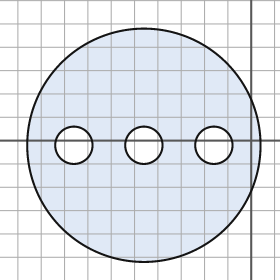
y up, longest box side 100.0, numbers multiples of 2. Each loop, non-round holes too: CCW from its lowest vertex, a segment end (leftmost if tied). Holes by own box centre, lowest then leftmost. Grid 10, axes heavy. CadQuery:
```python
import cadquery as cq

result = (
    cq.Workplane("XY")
    .moveTo(-46.0, -2.0)
    .circle(50.0)
    .moveTo(-76.0, -2.0)
    .circle(8.0)
    .moveTo(-46.0, -2.0)
    .circle(8.0)
    .moveTo(-16.0, -2.0)
    .circle(8.0)
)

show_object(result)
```